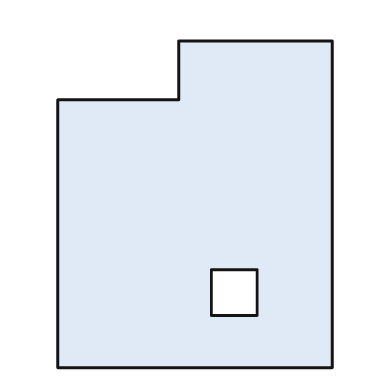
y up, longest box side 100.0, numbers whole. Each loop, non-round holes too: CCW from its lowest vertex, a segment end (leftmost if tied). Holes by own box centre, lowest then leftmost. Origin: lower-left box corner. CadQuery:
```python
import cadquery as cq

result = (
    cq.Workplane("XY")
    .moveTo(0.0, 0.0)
    .lineTo(84.0, 0.0)
    .lineTo(84.0, 100.0)
    .lineTo(37.0, 100.0)
    .lineTo(37.0, 82.0)
    .lineTo(0.0, 82.0)
    .close()
    .moveTo(47.0, 16.0)
    .lineTo(61.0, 16.0)
    .lineTo(61.0, 30.0)
    .lineTo(47.0, 30.0)
    .close()
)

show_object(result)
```